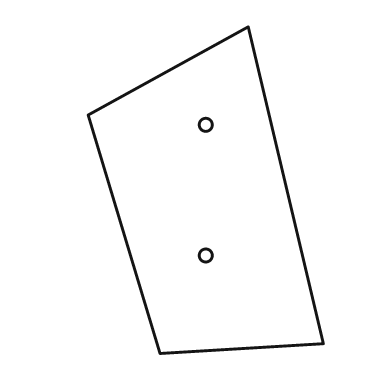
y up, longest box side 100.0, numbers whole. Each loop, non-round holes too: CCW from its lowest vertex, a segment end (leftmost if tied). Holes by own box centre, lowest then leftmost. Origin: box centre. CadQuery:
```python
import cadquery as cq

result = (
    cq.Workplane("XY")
    .moveTo(-14.0, -50.0)
    .lineTo(36.0, -47.0)
    .lineTo(13.0, 50.0)
    .lineTo(-36.0, 23.0)
    .close()
    .moveTo(0.0, -20.0)
    .circle(2.0)
    .moveTo(0.0, 20.0)
    .circle(2.0)
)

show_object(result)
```